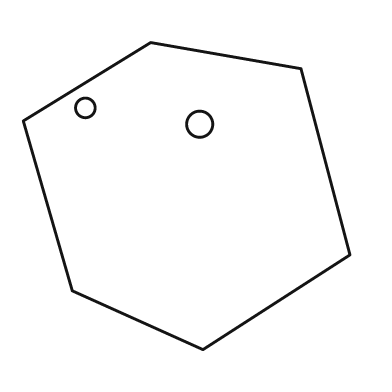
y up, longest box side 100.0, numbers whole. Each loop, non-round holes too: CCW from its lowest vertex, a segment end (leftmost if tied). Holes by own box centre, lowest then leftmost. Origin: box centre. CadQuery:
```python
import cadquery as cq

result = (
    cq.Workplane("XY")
    .moveTo(5.0, -47.0)
    .lineTo(50.0, -18.0)
    .lineTo(35.0, 39.0)
    .lineTo(-11.0, 47.0)
    .lineTo(-50.0, 23.0)
    .lineTo(-35.0, -29.0)
    .close()
    .moveTo(4.0, 22.0)
    .circle(4.0)
    .moveTo(-31.0, 27.0)
    .circle(3.0)
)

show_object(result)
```